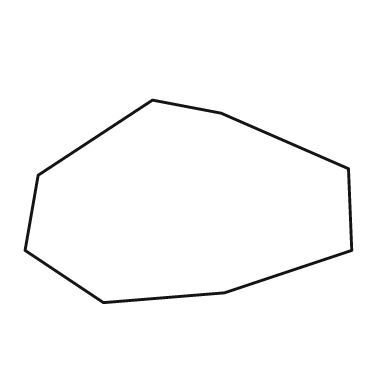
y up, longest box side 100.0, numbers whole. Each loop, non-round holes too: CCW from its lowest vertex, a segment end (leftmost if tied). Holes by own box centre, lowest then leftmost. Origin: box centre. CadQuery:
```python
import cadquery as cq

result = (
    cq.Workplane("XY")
    .moveTo(-26.0, -31.0)
    .lineTo(11.0, -28.0)
    .lineTo(50.0, -15.0)
    .lineTo(49.0, 10.0)
    .lineTo(10.0, 27.0)
    .lineTo(-11.0, 31.0)
    .lineTo(-46.0, 8.0)
    .lineTo(-50.0, -15.0)
    .close()
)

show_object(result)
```